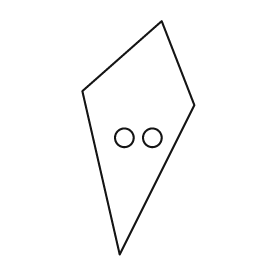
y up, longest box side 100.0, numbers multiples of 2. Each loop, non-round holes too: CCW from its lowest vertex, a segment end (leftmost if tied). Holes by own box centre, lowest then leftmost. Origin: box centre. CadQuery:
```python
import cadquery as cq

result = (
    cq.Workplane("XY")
    .moveTo(-8.0, -50.0)
    .lineTo(24.0, 14.0)
    .lineTo(10.0, 50.0)
    .lineTo(-24.0, 20.0)
    .close()
    .moveTo(-6.0, 0.0)
    .circle(4.0)
    .moveTo(6.0, 0.0)
    .circle(4.0)
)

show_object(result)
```